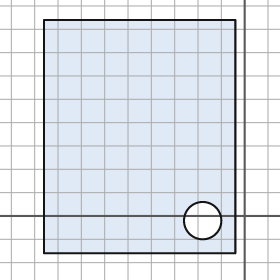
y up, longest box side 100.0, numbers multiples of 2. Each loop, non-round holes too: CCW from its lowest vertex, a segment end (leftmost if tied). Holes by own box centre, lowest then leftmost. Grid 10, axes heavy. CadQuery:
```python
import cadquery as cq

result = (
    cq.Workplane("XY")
    .moveTo(-86.0, -16.0)
    .lineTo(-4.0, -16.0)
    .lineTo(-4.0, 84.0)
    .lineTo(-86.0, 84.0)
    .close()
    .moveTo(-18.0, -2.0)
    .circle(8.0)
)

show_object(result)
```